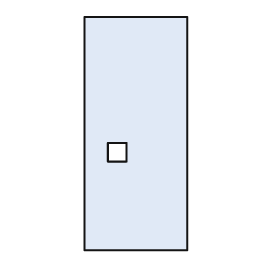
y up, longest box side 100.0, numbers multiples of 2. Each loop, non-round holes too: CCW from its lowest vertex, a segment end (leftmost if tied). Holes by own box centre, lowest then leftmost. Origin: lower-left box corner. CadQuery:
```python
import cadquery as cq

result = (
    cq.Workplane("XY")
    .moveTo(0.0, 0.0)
    .lineTo(44.0, 0.0)
    .lineTo(44.0, 100.0)
    .lineTo(0.0, 100.0)
    .close()
    .moveTo(10.0, 38.0)
    .lineTo(18.0, 38.0)
    .lineTo(18.0, 46.0)
    .lineTo(10.0, 46.0)
    .close()
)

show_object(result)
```